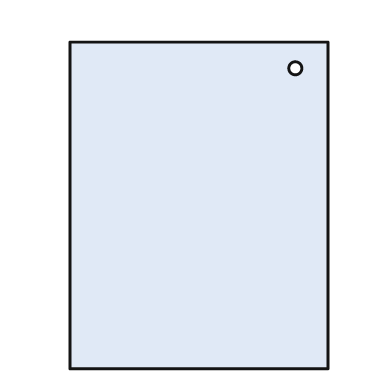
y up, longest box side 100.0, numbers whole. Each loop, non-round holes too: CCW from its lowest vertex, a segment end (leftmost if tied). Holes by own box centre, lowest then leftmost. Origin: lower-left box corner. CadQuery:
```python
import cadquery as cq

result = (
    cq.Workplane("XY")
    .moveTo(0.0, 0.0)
    .lineTo(79.0, 0.0)
    .lineTo(79.0, 100.0)
    .lineTo(0.0, 100.0)
    .close()
    .moveTo(69.0, 92.0)
    .circle(2.0)
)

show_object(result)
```